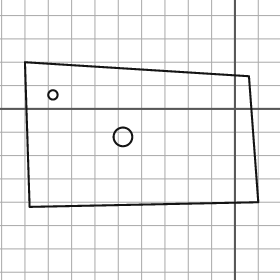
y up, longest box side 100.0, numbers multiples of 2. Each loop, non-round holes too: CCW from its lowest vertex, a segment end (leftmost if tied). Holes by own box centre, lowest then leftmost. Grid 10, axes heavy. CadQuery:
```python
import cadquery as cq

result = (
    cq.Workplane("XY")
    .moveTo(-88.0, -42.0)
    .lineTo(10.0, -40.0)
    .lineTo(6.0, 14.0)
    .lineTo(-90.0, 20.0)
    .close()
    .moveTo(-48.0, -12.0)
    .circle(4.0)
    .moveTo(-78.0, 6.0)
    .circle(2.0)
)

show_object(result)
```